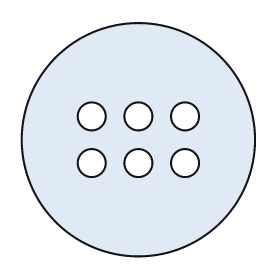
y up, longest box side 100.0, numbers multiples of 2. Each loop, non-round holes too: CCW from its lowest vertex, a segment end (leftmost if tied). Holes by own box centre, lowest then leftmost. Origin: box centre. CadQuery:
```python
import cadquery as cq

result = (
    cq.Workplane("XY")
    .moveTo(0.0, 0.0)
    .circle(50.0)
    .moveTo(-20.0, -10.0)
    .circle(6.0)
    .moveTo(0.0, -10.0)
    .circle(6.0)
    .moveTo(20.0, -10.0)
    .circle(6.0)
    .moveTo(-20.0, 10.0)
    .circle(6.0)
    .moveTo(0.0, 10.0)
    .circle(6.0)
    .moveTo(20.0, 10.0)
    .circle(6.0)
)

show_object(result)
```